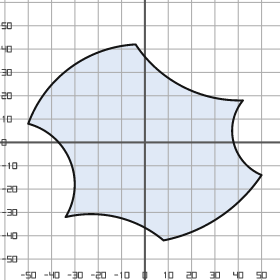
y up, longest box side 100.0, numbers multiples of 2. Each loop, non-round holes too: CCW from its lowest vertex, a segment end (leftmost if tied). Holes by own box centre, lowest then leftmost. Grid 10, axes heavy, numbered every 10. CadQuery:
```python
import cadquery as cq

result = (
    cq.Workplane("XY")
    .moveTo(8.0, -42.0)
    .threePointArc((32.0, -32.0), (50.0, -14.0))
    .threePointArc((38.0, 0.0), (42.0, 18.0))
    .threePointArc((16.0, 24.0), (-4.0, 42.0))
    .threePointArc((-32.0, 32.0), (-50.0, 8.0))
    .threePointArc((-32.0, -8.0), (-34.0, -32.0))
    .threePointArc((-12.0, -32.0), (8.0, -42.0))
    .close()
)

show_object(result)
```